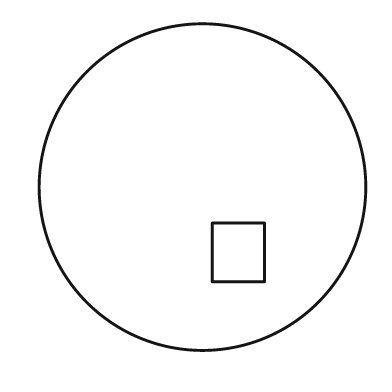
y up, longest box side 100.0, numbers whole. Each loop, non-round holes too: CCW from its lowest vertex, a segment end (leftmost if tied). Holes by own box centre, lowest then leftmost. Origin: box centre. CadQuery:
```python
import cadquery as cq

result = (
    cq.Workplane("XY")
    .moveTo(0.0, 0.0)
    .circle(50.0)
    .moveTo(3.0, -29.0)
    .lineTo(19.0, -29.0)
    .lineTo(19.0, -11.0)
    .lineTo(3.0, -11.0)
    .close()
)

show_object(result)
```